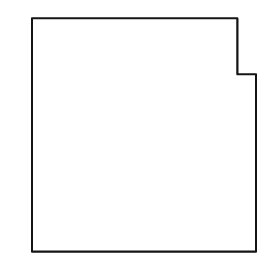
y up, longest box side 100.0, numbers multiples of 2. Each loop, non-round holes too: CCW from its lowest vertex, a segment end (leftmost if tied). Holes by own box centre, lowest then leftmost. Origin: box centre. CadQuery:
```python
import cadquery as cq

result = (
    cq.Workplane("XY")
    .moveTo(-48.0, -50.0)
    .lineTo(48.0, -50.0)
    .lineTo(48.0, 26.0)
    .lineTo(40.0, 26.0)
    .lineTo(40.0, 50.0)
    .lineTo(-48.0, 50.0)
    .close()
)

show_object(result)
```